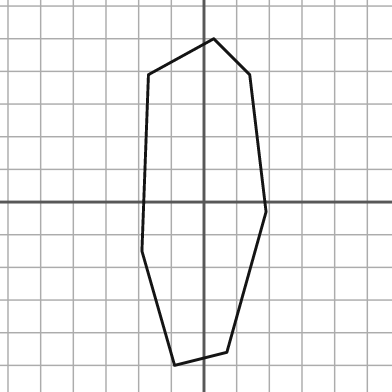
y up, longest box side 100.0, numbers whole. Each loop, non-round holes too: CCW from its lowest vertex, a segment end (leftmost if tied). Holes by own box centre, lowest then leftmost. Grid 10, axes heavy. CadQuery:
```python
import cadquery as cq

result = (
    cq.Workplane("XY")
    .moveTo(-9.0, -50.0)
    .lineTo(7.0, -46.0)
    .lineTo(19.0, -3.0)
    .lineTo(14.0, 39.0)
    .lineTo(3.0, 50.0)
    .lineTo(-17.0, 39.0)
    .lineTo(-19.0, -15.0)
    .close()
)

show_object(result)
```